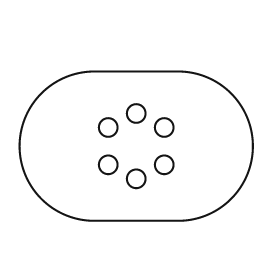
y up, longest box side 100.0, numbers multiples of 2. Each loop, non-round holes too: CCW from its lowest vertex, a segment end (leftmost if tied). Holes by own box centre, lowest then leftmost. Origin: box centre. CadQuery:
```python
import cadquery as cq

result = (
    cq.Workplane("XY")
    .moveTo(-18.0, -32.0)
    .lineTo(18.0, -32.0)
    .threePointArc((50.0, 0.0), (18.0, 32.0))
    .lineTo(-18.0, 32.0)
    .threePointArc((-50.0, 0.0), (-18.0, -32.0))
    .close()
    .moveTo(0.0, -14.0)
    .circle(4.0)
    .moveTo(-12.0, -8.0)
    .circle(4.0)
    .moveTo(12.0, -8.0)
    .circle(4.0)
    .moveTo(-12.0, 8.0)
    .circle(4.0)
    .moveTo(12.0, 8.0)
    .circle(4.0)
    .moveTo(0.0, 14.0)
    .circle(4.0)
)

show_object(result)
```